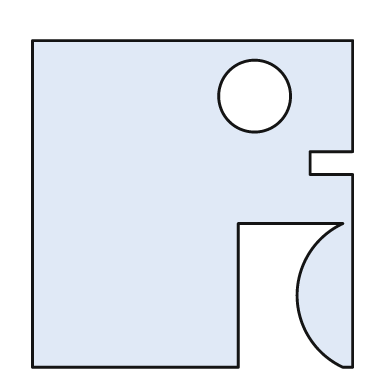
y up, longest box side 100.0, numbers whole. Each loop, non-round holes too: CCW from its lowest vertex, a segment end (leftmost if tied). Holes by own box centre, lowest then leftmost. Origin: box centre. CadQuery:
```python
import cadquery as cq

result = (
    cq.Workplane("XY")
    .moveTo(-49.0, -50.0)
    .lineTo(14.0, -50.0)
    .lineTo(14.0, -6.0)
    .lineTo(46.0, -6.0)
    .threePointArc((32.0, -28.0), (46.0, -50.0))
    .lineTo(49.0, -50.0)
    .lineTo(49.0, 9.0)
    .lineTo(36.0, 9.0)
    .lineTo(36.0, 16.0)
    .lineTo(49.0, 16.0)
    .lineTo(49.0, 50.0)
    .lineTo(-49.0, 50.0)
    .close()
    .moveTo(19.0, 33.0)
    .circle(11.0)
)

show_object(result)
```